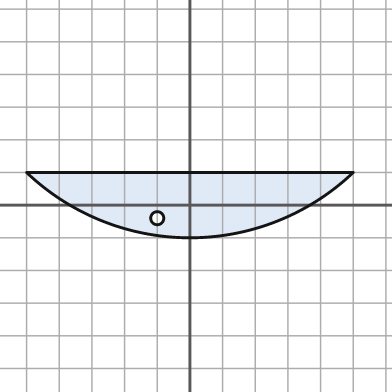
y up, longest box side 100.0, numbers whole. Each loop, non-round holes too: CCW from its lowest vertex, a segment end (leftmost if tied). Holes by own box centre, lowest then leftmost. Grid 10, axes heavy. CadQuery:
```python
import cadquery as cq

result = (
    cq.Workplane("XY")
    .moveTo(-50.0, 10.0)
    .threePointArc((0.0, -10.0), (50.0, 10.0))
    .close()
    .moveTo(-10.0, -4.0)
    .circle(2.0)
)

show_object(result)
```